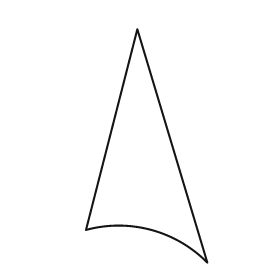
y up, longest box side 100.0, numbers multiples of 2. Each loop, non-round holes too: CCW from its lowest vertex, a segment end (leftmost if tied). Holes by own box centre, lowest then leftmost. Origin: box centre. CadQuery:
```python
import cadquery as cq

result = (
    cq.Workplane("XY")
    .moveTo(26.0, -50.0)
    .lineTo(-4.0, 50.0)
    .lineTo(-26.0, -36.0)
    .threePointArc((2.0, -36.0), (26.0, -50.0))
    .close()
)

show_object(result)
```